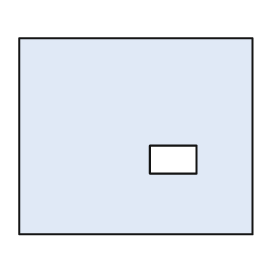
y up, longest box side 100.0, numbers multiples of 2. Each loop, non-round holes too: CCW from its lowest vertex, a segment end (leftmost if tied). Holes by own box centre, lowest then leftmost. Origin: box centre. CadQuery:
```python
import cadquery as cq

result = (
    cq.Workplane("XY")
    .moveTo(-50.0, -42.0)
    .lineTo(50.0, -42.0)
    .lineTo(50.0, 42.0)
    .lineTo(-50.0, 42.0)
    .close()
    .moveTo(6.0, -16.0)
    .lineTo(26.0, -16.0)
    .lineTo(26.0, -4.0)
    .lineTo(6.0, -4.0)
    .close()
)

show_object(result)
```